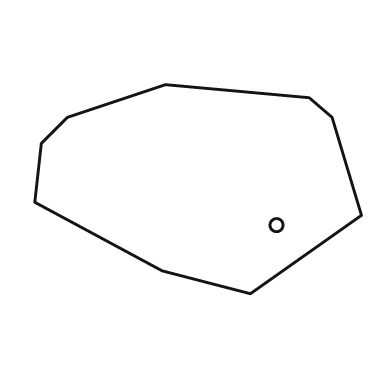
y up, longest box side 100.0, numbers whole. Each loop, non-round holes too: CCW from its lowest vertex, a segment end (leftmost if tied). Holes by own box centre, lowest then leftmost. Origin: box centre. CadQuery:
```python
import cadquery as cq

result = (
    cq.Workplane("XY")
    .moveTo(16.0, -32.0)
    .lineTo(50.0, -8.0)
    .lineTo(41.0, 22.0)
    .lineTo(34.0, 28.0)
    .lineTo(-10.0, 32.0)
    .lineTo(-40.0, 22.0)
    .lineTo(-48.0, 14.0)
    .lineTo(-50.0, -4.0)
    .lineTo(-11.0, -25.0)
    .close()
    .moveTo(24.0, -11.0)
    .circle(2.0)
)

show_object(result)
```